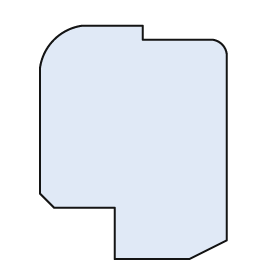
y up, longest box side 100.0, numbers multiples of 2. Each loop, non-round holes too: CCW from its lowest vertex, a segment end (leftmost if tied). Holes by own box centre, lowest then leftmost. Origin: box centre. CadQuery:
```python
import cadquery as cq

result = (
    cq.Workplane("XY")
    .moveTo(-8.0, -50.0)
    .lineTo(24.0, -50.0)
    .lineTo(40.0, -42.0)
    .lineTo(40.0, 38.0)
    .threePointArc((38.0, 42.0), (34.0, 44.0))
    .lineTo(4.0, 44.0)
    .lineTo(4.0, 50.0)
    .lineTo(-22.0, 50.0)
    .threePointArc((-34.0, 44.0), (-40.0, 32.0))
    .lineTo(-40.0, -22.0)
    .lineTo(-34.0, -28.0)
    .lineTo(-8.0, -28.0)
    .close()
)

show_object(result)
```